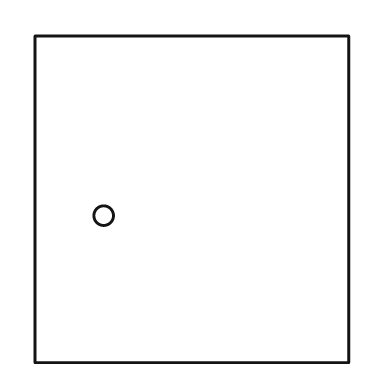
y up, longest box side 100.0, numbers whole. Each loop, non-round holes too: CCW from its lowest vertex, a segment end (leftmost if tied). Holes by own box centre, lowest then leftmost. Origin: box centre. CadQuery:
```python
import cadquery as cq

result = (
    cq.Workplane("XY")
    .moveTo(-48.0, -50.0)
    .lineTo(48.0, -50.0)
    .lineTo(48.0, 50.0)
    .lineTo(-48.0, 50.0)
    .close()
    .moveTo(-27.0, -5.0)
    .circle(3.0)
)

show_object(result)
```